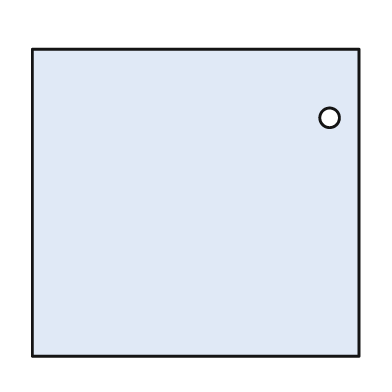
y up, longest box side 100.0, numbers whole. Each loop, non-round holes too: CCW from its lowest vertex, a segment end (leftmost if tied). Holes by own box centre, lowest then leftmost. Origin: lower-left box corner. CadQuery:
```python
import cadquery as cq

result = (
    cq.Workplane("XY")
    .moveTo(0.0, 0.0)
    .lineTo(100.0, 0.0)
    .lineTo(100.0, 94.0)
    .lineTo(0.0, 94.0)
    .close()
    .moveTo(91.0, 73.0)
    .circle(3.0)
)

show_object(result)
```